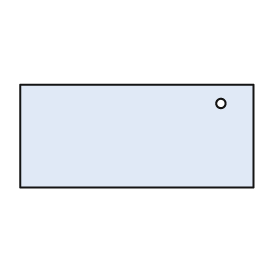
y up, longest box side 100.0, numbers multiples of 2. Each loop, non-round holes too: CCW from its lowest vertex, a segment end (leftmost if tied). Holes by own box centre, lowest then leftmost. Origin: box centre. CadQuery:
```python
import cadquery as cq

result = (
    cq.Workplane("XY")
    .moveTo(-50.0, -22.0)
    .lineTo(50.0, -22.0)
    .lineTo(50.0, 22.0)
    .lineTo(-50.0, 22.0)
    .close()
    .moveTo(36.0, 14.0)
    .circle(2.0)
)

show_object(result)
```